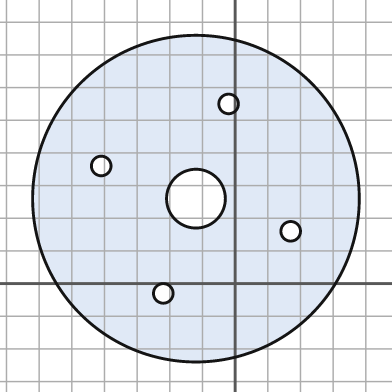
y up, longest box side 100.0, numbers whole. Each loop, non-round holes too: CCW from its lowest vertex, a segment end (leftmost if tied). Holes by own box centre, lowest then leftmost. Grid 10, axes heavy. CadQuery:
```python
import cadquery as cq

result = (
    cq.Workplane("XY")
    .moveTo(-12.0, 26.0)
    .circle(50.0)
    .moveTo(-22.0, -3.0)
    .circle(3.0)
    .moveTo(17.0, 16.0)
    .circle(3.0)
    .moveTo(-12.0, 26.0)
    .circle(9.0)
    .moveTo(-41.0, 36.0)
    .circle(3.0)
    .moveTo(-2.0, 55.0)
    .circle(3.0)
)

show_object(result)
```